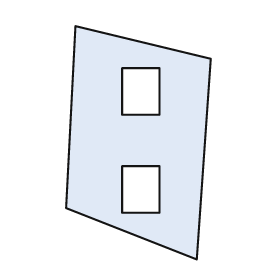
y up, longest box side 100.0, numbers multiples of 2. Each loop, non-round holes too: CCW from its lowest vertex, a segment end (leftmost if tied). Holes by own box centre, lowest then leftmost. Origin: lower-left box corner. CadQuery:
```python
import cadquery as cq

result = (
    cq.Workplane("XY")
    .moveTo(56.0, 0.0)
    .lineTo(62.0, 86.0)
    .lineTo(4.0, 100.0)
    .lineTo(0.0, 22.0)
    .close()
    .moveTo(24.0, 20.0)
    .lineTo(40.0, 20.0)
    .lineTo(40.0, 40.0)
    .lineTo(24.0, 40.0)
    .close()
    .moveTo(24.0, 62.0)
    .lineTo(40.0, 62.0)
    .lineTo(40.0, 82.0)
    .lineTo(24.0, 82.0)
    .close()
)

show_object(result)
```